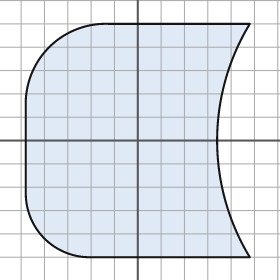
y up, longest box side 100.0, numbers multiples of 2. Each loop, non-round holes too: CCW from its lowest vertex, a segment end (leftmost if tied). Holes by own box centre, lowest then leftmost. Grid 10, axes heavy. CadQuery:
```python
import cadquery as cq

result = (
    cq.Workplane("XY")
    .moveTo(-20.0, -50.0)
    .lineTo(48.0, -50.0)
    .threePointArc((34.0, 0.0), (48.0, 50.0))
    .lineTo(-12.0, 50.0)
    .threePointArc((-38.0, 40.0), (-48.0, 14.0))
    .lineTo(-48.0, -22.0)
    .threePointArc((-40.0, -42.0), (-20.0, -50.0))
    .close()
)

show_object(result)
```